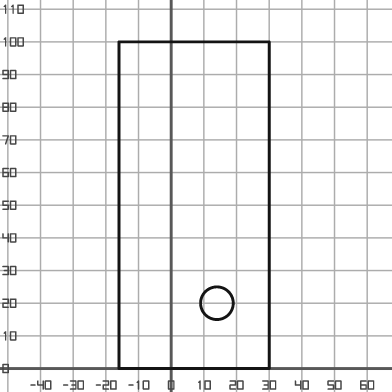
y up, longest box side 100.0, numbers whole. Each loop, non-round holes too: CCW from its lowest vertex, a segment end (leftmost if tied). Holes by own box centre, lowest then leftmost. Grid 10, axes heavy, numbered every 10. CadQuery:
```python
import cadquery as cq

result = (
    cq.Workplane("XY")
    .moveTo(-16.0, 0.0)
    .lineTo(30.0, 0.0)
    .lineTo(30.0, 100.0)
    .lineTo(-16.0, 100.0)
    .close()
    .moveTo(14.0, 20.0)
    .circle(5.0)
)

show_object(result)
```